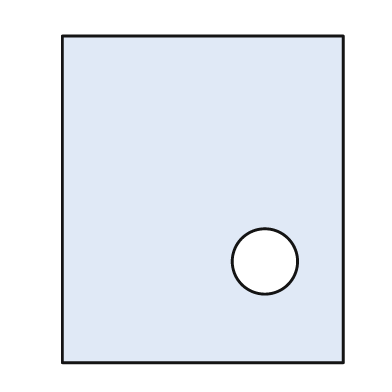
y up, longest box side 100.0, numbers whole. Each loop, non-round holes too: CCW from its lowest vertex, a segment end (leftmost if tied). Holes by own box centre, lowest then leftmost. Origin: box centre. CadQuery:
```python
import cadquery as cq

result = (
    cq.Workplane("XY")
    .moveTo(-43.0, -50.0)
    .lineTo(43.0, -50.0)
    .lineTo(43.0, 50.0)
    .lineTo(-43.0, 50.0)
    .close()
    .moveTo(19.0, -19.0)
    .circle(10.0)
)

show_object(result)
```